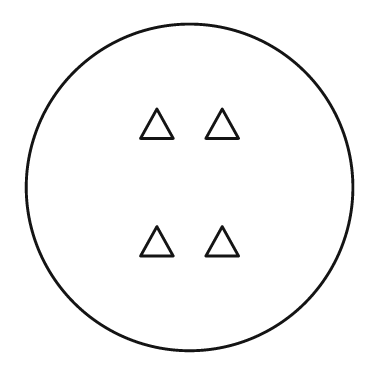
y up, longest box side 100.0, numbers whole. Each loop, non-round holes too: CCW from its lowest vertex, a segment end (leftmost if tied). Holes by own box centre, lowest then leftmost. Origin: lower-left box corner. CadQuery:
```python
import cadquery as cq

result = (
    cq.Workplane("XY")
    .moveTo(50.0, 50.0)
    .circle(50.0)
    .moveTo(35.0, 29.0)
    .lineTo(45.0, 29.0)
    .lineTo(40.0, 38.0)
    .close()
    .moveTo(55.0, 29.0)
    .lineTo(65.0, 29.0)
    .lineTo(60.0, 38.0)
    .close()
    .moveTo(35.0, 65.0)
    .lineTo(45.0, 65.0)
    .lineTo(40.0, 74.0)
    .close()
    .moveTo(55.0, 65.0)
    .lineTo(65.0, 65.0)
    .lineTo(60.0, 74.0)
    .close()
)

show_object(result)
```